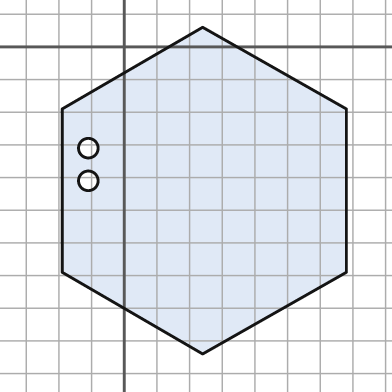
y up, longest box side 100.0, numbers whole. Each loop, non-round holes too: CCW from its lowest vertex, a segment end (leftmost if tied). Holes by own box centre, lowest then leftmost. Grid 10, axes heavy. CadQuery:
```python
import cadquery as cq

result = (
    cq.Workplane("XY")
    .moveTo(24.0, -94.0)
    .lineTo(68.0, -69.0)
    .lineTo(68.0, -19.0)
    .lineTo(24.0, 6.0)
    .lineTo(-19.0, -19.0)
    .lineTo(-19.0, -69.0)
    .close()
    .moveTo(-11.0, -41.0)
    .circle(3.0)
    .moveTo(-11.0, -31.0)
    .circle(3.0)
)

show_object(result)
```